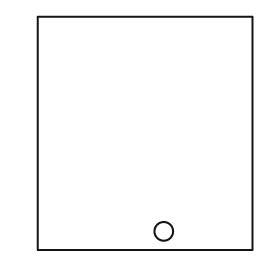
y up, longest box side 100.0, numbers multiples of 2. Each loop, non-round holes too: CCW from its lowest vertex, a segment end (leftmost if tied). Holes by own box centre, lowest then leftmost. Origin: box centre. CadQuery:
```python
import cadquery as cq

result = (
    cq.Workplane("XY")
    .moveTo(-46.0, -50.0)
    .lineTo(46.0, -50.0)
    .lineTo(46.0, 50.0)
    .lineTo(-46.0, 50.0)
    .close()
    .moveTo(8.0, -42.0)
    .circle(4.0)
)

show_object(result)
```